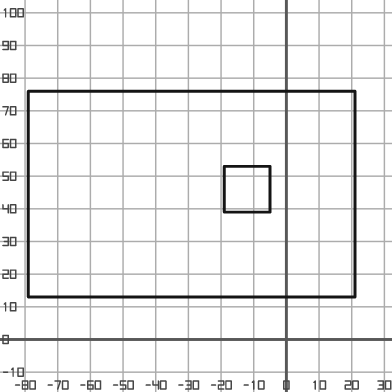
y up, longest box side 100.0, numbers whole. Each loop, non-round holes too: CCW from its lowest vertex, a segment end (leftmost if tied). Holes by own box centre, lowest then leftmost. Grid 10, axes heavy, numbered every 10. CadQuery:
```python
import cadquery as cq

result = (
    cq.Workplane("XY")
    .moveTo(-79.0, 13.0)
    .lineTo(21.0, 13.0)
    .lineTo(21.0, 76.0)
    .lineTo(-79.0, 76.0)
    .close()
    .moveTo(-19.0, 39.0)
    .lineTo(-5.0, 39.0)
    .lineTo(-5.0, 53.0)
    .lineTo(-19.0, 53.0)
    .close()
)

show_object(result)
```